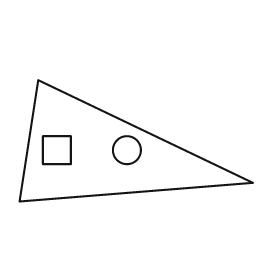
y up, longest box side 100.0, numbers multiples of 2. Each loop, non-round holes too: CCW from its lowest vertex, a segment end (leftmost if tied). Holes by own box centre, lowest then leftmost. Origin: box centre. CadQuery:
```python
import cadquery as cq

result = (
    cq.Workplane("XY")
    .moveTo(-50.0, -26.0)
    .lineTo(50.0, -18.0)
    .lineTo(-42.0, 26.0)
    .close()
    .moveTo(-40.0, -10.0)
    .lineTo(-28.0, -10.0)
    .lineTo(-28.0, 2.0)
    .lineTo(-40.0, 2.0)
    .close()
    .moveTo(-4.0, -4.0)
    .circle(6.0)
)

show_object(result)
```